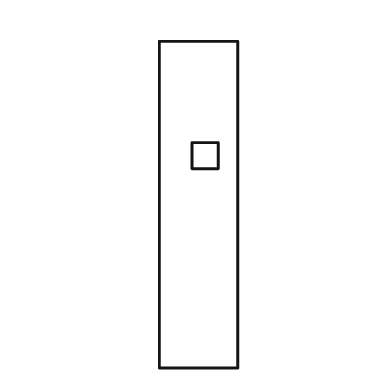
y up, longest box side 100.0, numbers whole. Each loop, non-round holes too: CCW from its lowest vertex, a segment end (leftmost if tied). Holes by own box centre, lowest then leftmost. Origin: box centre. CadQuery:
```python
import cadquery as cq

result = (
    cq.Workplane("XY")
    .moveTo(-12.0, -50.0)
    .lineTo(12.0, -50.0)
    .lineTo(12.0, 50.0)
    .lineTo(-12.0, 50.0)
    .close()
    .moveTo(-2.0, 11.0)
    .lineTo(6.0, 11.0)
    .lineTo(6.0, 19.0)
    .lineTo(-2.0, 19.0)
    .close()
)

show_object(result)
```